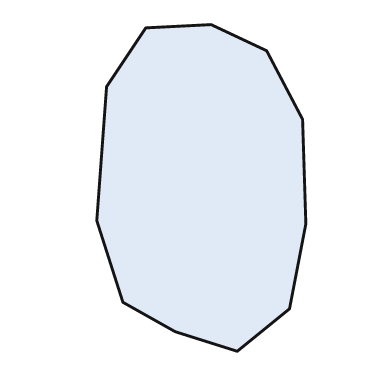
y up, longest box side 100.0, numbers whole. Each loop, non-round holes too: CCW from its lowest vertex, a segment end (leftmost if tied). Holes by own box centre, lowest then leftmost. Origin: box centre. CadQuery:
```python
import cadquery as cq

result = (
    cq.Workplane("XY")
    .moveTo(11.0, -50.0)
    .lineTo(27.0, -37.0)
    .lineTo(32.0, -11.0)
    .lineTo(31.0, 21.0)
    .lineTo(20.0, 42.0)
    .lineTo(3.0, 50.0)
    .lineTo(-17.0, 49.0)
    .lineTo(-29.0, 31.0)
    .lineTo(-32.0, -10.0)
    .lineTo(-24.0, -35.0)
    .lineTo(-8.0, -44.0)
    .close()
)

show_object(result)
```